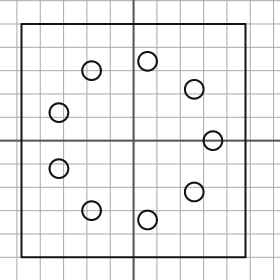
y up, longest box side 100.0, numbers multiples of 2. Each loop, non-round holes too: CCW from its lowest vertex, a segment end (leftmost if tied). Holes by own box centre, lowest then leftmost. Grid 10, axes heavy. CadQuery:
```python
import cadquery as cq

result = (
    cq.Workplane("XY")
    .moveTo(-48.0, -50.0)
    .lineTo(48.0, -50.0)
    .lineTo(48.0, 50.0)
    .lineTo(-48.0, 50.0)
    .close()
    .moveTo(6.0, -34.0)
    .circle(4.0)
    .moveTo(-18.0, -30.0)
    .circle(4.0)
    .moveTo(26.0, -22.0)
    .circle(4.0)
    .moveTo(-32.0, -12.0)
    .circle(4.0)
    .moveTo(34.0, 0.0)
    .circle(4.0)
    .moveTo(-32.0, 12.0)
    .circle(4.0)
    .moveTo(26.0, 22.0)
    .circle(4.0)
    .moveTo(-18.0, 30.0)
    .circle(4.0)
    .moveTo(6.0, 34.0)
    .circle(4.0)
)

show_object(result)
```